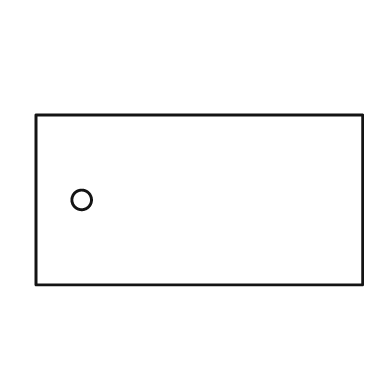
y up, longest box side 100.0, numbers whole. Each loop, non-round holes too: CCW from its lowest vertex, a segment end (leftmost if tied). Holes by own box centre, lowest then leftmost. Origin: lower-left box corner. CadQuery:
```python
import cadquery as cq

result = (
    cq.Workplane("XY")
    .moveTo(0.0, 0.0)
    .lineTo(100.0, 0.0)
    .lineTo(100.0, 52.0)
    .lineTo(0.0, 52.0)
    .close()
    .moveTo(14.0, 26.0)
    .circle(3.0)
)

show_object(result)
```